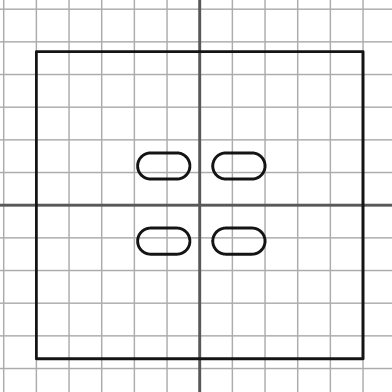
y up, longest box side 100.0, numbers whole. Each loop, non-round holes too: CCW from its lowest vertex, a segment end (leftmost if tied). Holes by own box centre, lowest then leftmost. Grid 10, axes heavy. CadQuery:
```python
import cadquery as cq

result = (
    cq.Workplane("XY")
    .moveTo(-50.0, -47.0)
    .lineTo(50.0, -47.0)
    .lineTo(50.0, 47.0)
    .lineTo(-50.0, 47.0)
    .close()
    .moveTo(-15.0, -15.0)
    .lineTo(-7.0, -15.0)
    .threePointArc((-3.0, -11.0), (-7.0, -7.0))
    .lineTo(-15.0, -7.0)
    .threePointArc((-19.0, -11.0), (-15.0, -15.0))
    .close()
    .moveTo(8.0, -15.0)
    .lineTo(16.0, -15.0)
    .threePointArc((20.0, -11.0), (16.0, -7.0))
    .lineTo(8.0, -7.0)
    .threePointArc((4.0, -11.0), (8.0, -15.0))
    .close()
    .moveTo(-15.0, 8.0)
    .lineTo(-7.0, 8.0)
    .threePointArc((-3.0, 12.0), (-7.0, 16.0))
    .lineTo(-15.0, 16.0)
    .threePointArc((-19.0, 12.0), (-15.0, 8.0))
    .close()
    .moveTo(8.0, 8.0)
    .lineTo(16.0, 8.0)
    .threePointArc((20.0, 12.0), (16.0, 16.0))
    .lineTo(8.0, 16.0)
    .threePointArc((4.0, 12.0), (8.0, 8.0))
    .close()
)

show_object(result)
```